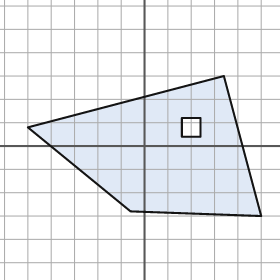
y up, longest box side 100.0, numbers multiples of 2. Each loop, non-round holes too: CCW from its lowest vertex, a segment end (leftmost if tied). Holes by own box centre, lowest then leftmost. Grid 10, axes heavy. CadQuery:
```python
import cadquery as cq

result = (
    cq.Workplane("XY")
    .moveTo(50.0, -30.0)
    .lineTo(34.0, 30.0)
    .lineTo(-50.0, 8.0)
    .lineTo(-6.0, -28.0)
    .close()
    .moveTo(16.0, 4.0)
    .lineTo(24.0, 4.0)
    .lineTo(24.0, 12.0)
    .lineTo(16.0, 12.0)
    .close()
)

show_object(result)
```